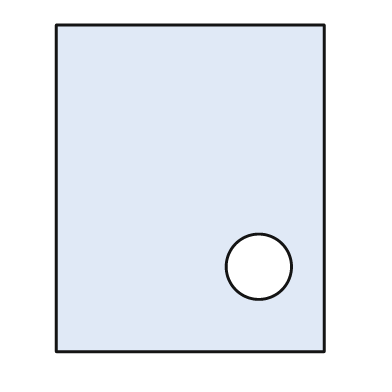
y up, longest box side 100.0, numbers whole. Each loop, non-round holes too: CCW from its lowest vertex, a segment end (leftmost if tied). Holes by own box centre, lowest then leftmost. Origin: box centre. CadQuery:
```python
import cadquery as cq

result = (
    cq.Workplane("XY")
    .moveTo(-41.0, -50.0)
    .lineTo(41.0, -50.0)
    .lineTo(41.0, 50.0)
    .lineTo(-41.0, 50.0)
    .close()
    .moveTo(21.0, -24.0)
    .circle(10.0)
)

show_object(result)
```